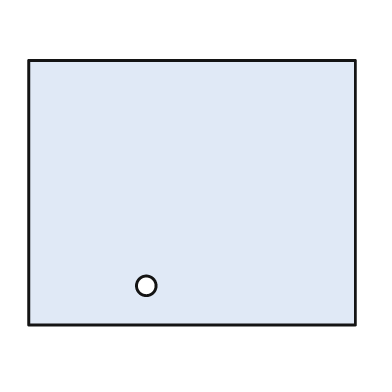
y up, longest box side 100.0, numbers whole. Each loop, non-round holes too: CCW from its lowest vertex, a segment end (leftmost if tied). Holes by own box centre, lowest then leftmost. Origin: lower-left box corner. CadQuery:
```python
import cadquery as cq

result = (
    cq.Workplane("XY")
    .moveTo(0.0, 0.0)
    .lineTo(100.0, 0.0)
    .lineTo(100.0, 81.0)
    .lineTo(0.0, 81.0)
    .close()
    .moveTo(36.0, 12.0)
    .circle(3.0)
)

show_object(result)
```